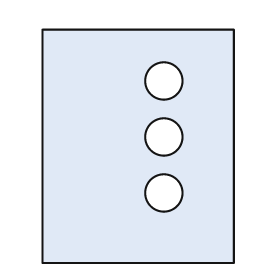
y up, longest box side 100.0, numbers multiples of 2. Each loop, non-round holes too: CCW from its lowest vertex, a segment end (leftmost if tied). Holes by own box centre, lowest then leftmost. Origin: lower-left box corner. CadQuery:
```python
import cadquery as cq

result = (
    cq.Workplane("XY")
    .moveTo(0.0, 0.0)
    .lineTo(82.0, 0.0)
    .lineTo(82.0, 100.0)
    .lineTo(0.0, 100.0)
    .close()
    .moveTo(52.0, 30.0)
    .circle(8.0)
    .moveTo(52.0, 54.0)
    .circle(8.0)
    .moveTo(52.0, 78.0)
    .circle(8.0)
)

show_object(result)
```